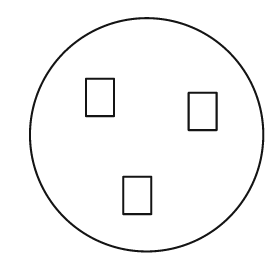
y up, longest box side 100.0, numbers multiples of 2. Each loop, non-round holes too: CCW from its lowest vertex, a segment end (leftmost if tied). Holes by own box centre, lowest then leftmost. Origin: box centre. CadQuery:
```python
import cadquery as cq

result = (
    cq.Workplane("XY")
    .moveTo(0.0, 0.0)
    .circle(50.0)
    .moveTo(-10.0, -34.0)
    .lineTo(2.0, -34.0)
    .lineTo(2.0, -18.0)
    .lineTo(-10.0, -18.0)
    .close()
    .moveTo(18.0, 2.0)
    .lineTo(30.0, 2.0)
    .lineTo(30.0, 18.0)
    .lineTo(18.0, 18.0)
    .close()
    .moveTo(-26.0, 8.0)
    .lineTo(-14.0, 8.0)
    .lineTo(-14.0, 24.0)
    .lineTo(-26.0, 24.0)
    .close()
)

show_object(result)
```